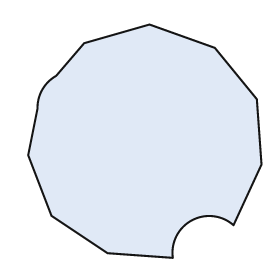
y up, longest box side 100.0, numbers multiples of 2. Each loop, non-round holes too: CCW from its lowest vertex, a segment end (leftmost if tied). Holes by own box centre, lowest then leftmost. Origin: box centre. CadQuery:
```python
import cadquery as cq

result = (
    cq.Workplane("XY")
    .moveTo(12.0, -50.0)
    .threePointArc((20.0, -34.0), (38.0, -36.0))
    .lineTo(50.0, -10.0)
    .lineTo(48.0, 18.0)
    .lineTo(30.0, 40.0)
    .lineTo(2.0, 50.0)
    .lineTo(-26.0, 42.0)
    .lineTo(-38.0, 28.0)
    .threePointArc((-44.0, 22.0), (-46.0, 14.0))
    .lineTo(-50.0, -6.0)
    .lineTo(-40.0, -32.0)
    .lineTo(-16.0, -48.0)
    .close()
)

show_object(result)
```